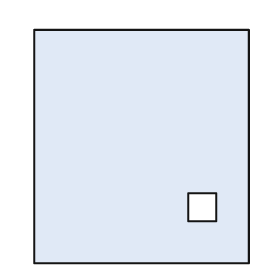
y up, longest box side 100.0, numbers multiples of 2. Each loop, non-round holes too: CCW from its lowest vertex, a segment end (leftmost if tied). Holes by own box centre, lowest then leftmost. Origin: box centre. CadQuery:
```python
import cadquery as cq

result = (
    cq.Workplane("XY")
    .moveTo(-46.0, -50.0)
    .lineTo(46.0, -50.0)
    .lineTo(46.0, 50.0)
    .lineTo(-46.0, 50.0)
    .close()
    .moveTo(20.0, -32.0)
    .lineTo(32.0, -32.0)
    .lineTo(32.0, -20.0)
    .lineTo(20.0, -20.0)
    .close()
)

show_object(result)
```